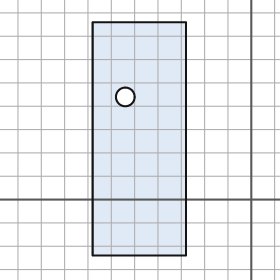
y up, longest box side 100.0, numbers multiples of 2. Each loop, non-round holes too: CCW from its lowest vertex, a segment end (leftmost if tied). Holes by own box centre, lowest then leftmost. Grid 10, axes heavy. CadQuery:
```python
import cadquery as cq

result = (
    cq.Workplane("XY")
    .moveTo(-68.0, -24.0)
    .lineTo(-28.0, -24.0)
    .lineTo(-28.0, 76.0)
    .lineTo(-68.0, 76.0)
    .close()
    .moveTo(-54.0, 44.0)
    .circle(4.0)
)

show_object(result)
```